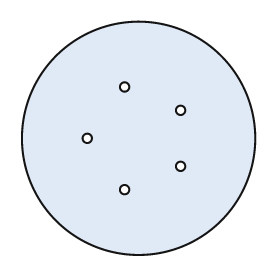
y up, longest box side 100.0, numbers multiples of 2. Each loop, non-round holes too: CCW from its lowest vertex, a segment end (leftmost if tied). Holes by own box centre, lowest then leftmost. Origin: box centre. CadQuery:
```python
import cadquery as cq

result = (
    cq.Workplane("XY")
    .moveTo(0.0, 0.0)
    .circle(50.0)
    .moveTo(-6.0, -22.0)
    .circle(2.0)
    .moveTo(18.0, -12.0)
    .circle(2.0)
    .moveTo(-22.0, 0.0)
    .circle(2.0)
    .moveTo(18.0, 12.0)
    .circle(2.0)
    .moveTo(-6.0, 22.0)
    .circle(2.0)
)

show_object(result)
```